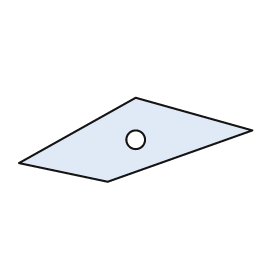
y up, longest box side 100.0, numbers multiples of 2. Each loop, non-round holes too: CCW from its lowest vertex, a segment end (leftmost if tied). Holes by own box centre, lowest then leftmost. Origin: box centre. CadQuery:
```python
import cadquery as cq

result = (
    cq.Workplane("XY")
    .moveTo(-12.0, -18.0)
    .lineTo(50.0, 4.0)
    .lineTo(0.0, 18.0)
    .lineTo(-50.0, -10.0)
    .close()
    .moveTo(0.0, 0.0)
    .circle(4.0)
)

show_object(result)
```